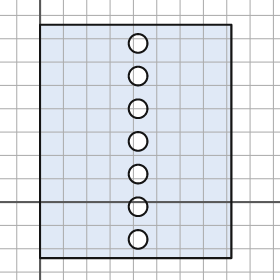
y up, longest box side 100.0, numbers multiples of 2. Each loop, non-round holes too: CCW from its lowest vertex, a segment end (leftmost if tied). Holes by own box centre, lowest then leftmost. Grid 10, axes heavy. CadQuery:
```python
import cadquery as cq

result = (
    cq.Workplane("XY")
    .moveTo(0.0, -24.0)
    .lineTo(82.0, -24.0)
    .lineTo(82.0, 76.0)
    .lineTo(0.0, 76.0)
    .close()
    .moveTo(42.0, -16.0)
    .circle(4.0)
    .moveTo(42.0, -2.0)
    .circle(4.0)
    .moveTo(42.0, 12.0)
    .circle(4.0)
    .moveTo(42.0, 26.0)
    .circle(4.0)
    .moveTo(42.0, 40.0)
    .circle(4.0)
    .moveTo(42.0, 54.0)
    .circle(4.0)
    .moveTo(42.0, 68.0)
    .circle(4.0)
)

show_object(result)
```